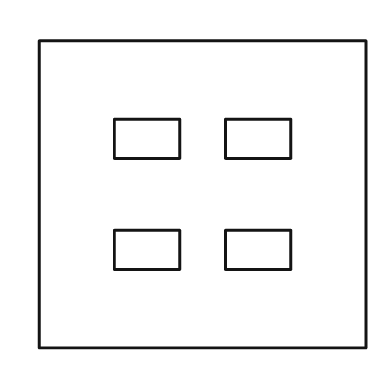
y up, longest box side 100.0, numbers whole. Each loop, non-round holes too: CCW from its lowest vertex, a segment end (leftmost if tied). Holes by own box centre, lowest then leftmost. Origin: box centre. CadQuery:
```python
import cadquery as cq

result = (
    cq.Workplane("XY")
    .moveTo(-50.0, -47.0)
    .lineTo(50.0, -47.0)
    .lineTo(50.0, 47.0)
    .lineTo(-50.0, 47.0)
    .close()
    .moveTo(-27.0, -23.0)
    .lineTo(-7.0, -23.0)
    .lineTo(-7.0, -11.0)
    .lineTo(-27.0, -11.0)
    .close()
    .moveTo(7.0, -23.0)
    .lineTo(27.0, -23.0)
    .lineTo(27.0, -11.0)
    .lineTo(7.0, -11.0)
    .close()
    .moveTo(-27.0, 11.0)
    .lineTo(-7.0, 11.0)
    .lineTo(-7.0, 23.0)
    .lineTo(-27.0, 23.0)
    .close()
    .moveTo(7.0, 11.0)
    .lineTo(27.0, 11.0)
    .lineTo(27.0, 23.0)
    .lineTo(7.0, 23.0)
    .close()
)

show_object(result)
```